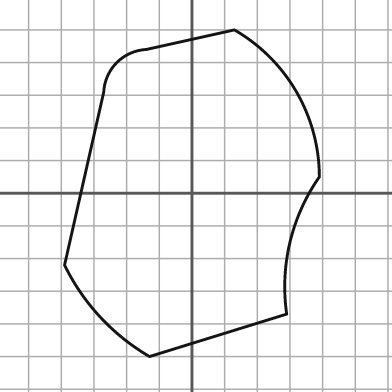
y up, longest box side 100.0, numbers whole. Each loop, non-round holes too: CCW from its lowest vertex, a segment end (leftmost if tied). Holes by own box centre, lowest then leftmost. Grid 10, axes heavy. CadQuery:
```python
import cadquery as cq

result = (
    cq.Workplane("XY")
    .moveTo(-13.0, -50.0)
    .lineTo(29.0, -37.0)
    .threePointArc((30.0, -15.0), (39.0, 5.0))
    .threePointArc((32.0, 31.0), (13.0, 50.0))
    .lineTo(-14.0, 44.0)
    .threePointArc((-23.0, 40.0), (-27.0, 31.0))
    .lineTo(-39.0, -22.0)
    .threePointArc((-28.0, -38.0), (-13.0, -50.0))
    .close()
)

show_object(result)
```